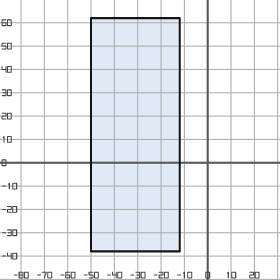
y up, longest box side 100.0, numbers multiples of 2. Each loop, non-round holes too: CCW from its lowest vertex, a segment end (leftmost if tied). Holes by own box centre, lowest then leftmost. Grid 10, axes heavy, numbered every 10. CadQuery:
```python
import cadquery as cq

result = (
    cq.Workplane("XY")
    .moveTo(-50.0, -38.0)
    .lineTo(-12.0, -38.0)
    .lineTo(-12.0, 62.0)
    .lineTo(-50.0, 62.0)
    .close()
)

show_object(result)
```